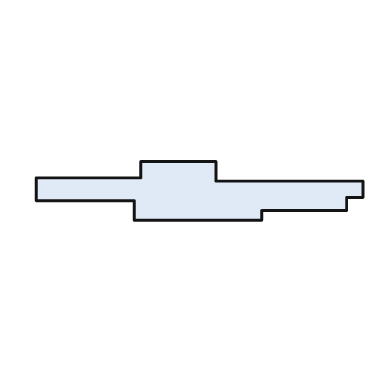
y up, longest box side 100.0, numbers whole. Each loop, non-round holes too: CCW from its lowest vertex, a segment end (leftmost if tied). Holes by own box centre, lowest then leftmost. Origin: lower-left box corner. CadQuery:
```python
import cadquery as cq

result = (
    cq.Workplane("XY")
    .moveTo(30.0, 0.0)
    .lineTo(69.0, 0.0)
    .lineTo(69.0, 3.0)
    .lineTo(95.0, 3.0)
    .lineTo(95.0, 7.0)
    .lineTo(100.0, 7.0)
    .lineTo(100.0, 12.0)
    .lineTo(55.0, 12.0)
    .lineTo(55.0, 18.0)
    .lineTo(32.0, 18.0)
    .lineTo(32.0, 13.0)
    .lineTo(0.0, 13.0)
    .lineTo(0.0, 6.0)
    .lineTo(30.0, 6.0)
    .close()
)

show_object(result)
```